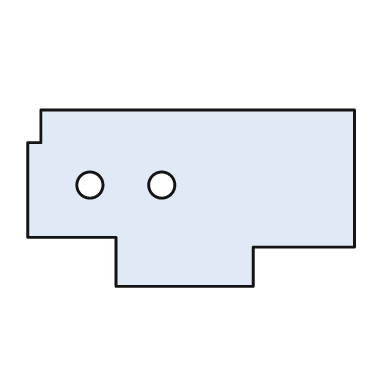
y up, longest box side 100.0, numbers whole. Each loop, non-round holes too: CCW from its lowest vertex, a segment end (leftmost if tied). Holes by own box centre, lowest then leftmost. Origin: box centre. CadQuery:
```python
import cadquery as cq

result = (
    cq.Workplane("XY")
    .moveTo(-23.0, -27.0)
    .lineTo(19.0, -27.0)
    .lineTo(19.0, -15.0)
    .lineTo(50.0, -15.0)
    .lineTo(50.0, 27.0)
    .lineTo(-46.0, 27.0)
    .lineTo(-46.0, 17.0)
    .lineTo(-50.0, 17.0)
    .lineTo(-50.0, -12.0)
    .lineTo(-23.0, -12.0)
    .close()
    .moveTo(-31.0, 4.0)
    .circle(4.0)
    .moveTo(-9.0, 4.0)
    .circle(4.0)
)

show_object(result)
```